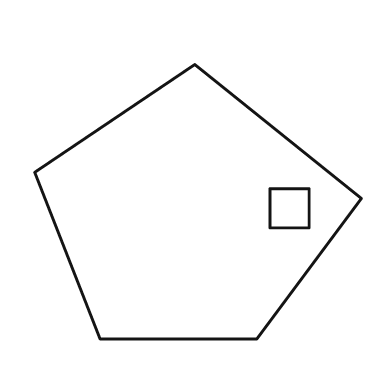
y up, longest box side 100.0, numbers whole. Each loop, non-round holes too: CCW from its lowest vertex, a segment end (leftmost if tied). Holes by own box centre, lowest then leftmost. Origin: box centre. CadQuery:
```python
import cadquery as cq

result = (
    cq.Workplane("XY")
    .moveTo(-30.0, -42.0)
    .lineTo(18.0, -42.0)
    .lineTo(50.0, 1.0)
    .lineTo(-1.0, 42.0)
    .lineTo(-50.0, 9.0)
    .close()
    .moveTo(22.0, -8.0)
    .lineTo(34.0, -8.0)
    .lineTo(34.0, 4.0)
    .lineTo(22.0, 4.0)
    .close()
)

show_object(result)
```